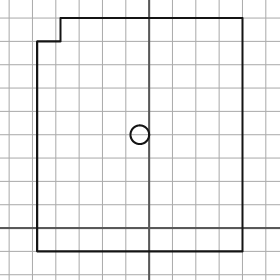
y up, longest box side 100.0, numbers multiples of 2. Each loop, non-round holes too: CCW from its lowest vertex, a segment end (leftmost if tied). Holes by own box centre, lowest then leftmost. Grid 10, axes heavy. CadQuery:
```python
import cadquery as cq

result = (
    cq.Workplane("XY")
    .moveTo(-48.0, -10.0)
    .lineTo(40.0, -10.0)
    .lineTo(40.0, 90.0)
    .lineTo(-38.0, 90.0)
    .lineTo(-38.0, 80.0)
    .lineTo(-48.0, 80.0)
    .close()
    .moveTo(-4.0, 40.0)
    .circle(4.0)
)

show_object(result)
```